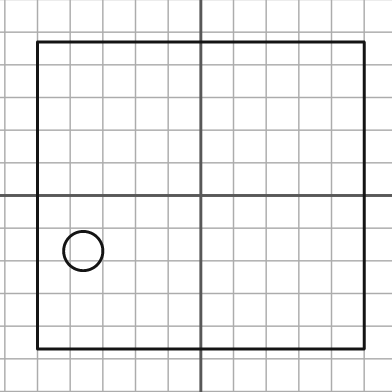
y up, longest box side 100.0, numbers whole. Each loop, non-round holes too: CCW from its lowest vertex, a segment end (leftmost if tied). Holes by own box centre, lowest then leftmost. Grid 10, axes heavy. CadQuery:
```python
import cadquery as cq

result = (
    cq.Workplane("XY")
    .moveTo(-50.0, -47.0)
    .lineTo(50.0, -47.0)
    .lineTo(50.0, 47.0)
    .lineTo(-50.0, 47.0)
    .close()
    .moveTo(-36.0, -17.0)
    .circle(6.0)
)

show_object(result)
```